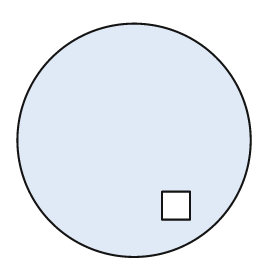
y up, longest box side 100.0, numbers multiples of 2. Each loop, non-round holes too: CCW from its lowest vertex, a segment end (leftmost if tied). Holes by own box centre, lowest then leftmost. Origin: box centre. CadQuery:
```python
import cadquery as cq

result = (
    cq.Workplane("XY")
    .moveTo(0.0, 0.0)
    .circle(50.0)
    .moveTo(12.0, -34.0)
    .lineTo(24.0, -34.0)
    .lineTo(24.0, -22.0)
    .lineTo(12.0, -22.0)
    .close()
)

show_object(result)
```